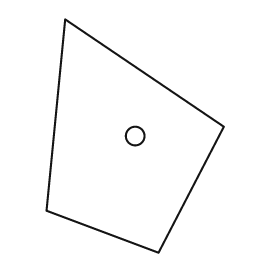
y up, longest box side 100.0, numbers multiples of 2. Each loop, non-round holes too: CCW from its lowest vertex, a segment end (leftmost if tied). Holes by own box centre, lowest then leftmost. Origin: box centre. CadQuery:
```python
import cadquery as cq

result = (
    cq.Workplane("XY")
    .moveTo(10.0, -50.0)
    .lineTo(38.0, 4.0)
    .lineTo(-30.0, 50.0)
    .lineTo(-38.0, -32.0)
    .close()
    .moveTo(0.0, 0.0)
    .circle(4.0)
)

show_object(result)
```